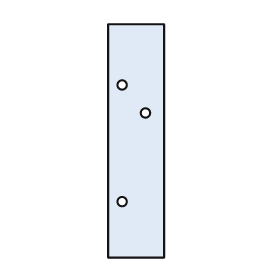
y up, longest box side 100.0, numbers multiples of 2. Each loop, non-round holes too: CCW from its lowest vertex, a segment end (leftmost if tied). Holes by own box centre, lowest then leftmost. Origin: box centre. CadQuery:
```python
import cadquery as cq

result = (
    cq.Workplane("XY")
    .moveTo(-12.0, -50.0)
    .lineTo(12.0, -50.0)
    .lineTo(12.0, 50.0)
    .lineTo(-12.0, 50.0)
    .close()
    .moveTo(-6.0, -26.0)
    .circle(2.0)
    .moveTo(4.0, 12.0)
    .circle(2.0)
    .moveTo(-6.0, 24.0)
    .circle(2.0)
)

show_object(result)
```